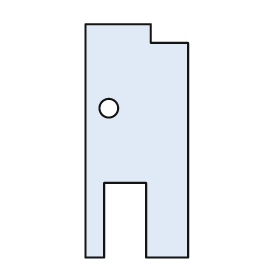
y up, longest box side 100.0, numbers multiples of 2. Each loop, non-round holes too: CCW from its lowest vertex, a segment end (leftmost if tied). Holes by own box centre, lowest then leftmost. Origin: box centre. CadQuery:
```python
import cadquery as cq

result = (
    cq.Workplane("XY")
    .moveTo(-22.0, -50.0)
    .lineTo(-14.0, -50.0)
    .lineTo(-14.0, -18.0)
    .lineTo(4.0, -18.0)
    .lineTo(4.0, -50.0)
    .lineTo(22.0, -50.0)
    .lineTo(22.0, 42.0)
    .lineTo(6.0, 42.0)
    .lineTo(6.0, 50.0)
    .lineTo(-22.0, 50.0)
    .close()
    .moveTo(-12.0, 14.0)
    .circle(4.0)
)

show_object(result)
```